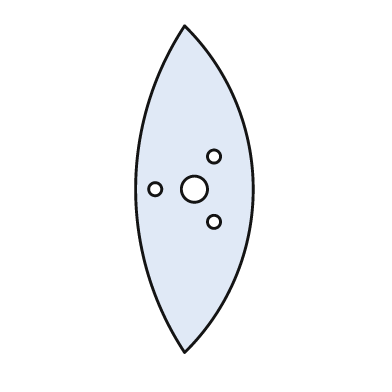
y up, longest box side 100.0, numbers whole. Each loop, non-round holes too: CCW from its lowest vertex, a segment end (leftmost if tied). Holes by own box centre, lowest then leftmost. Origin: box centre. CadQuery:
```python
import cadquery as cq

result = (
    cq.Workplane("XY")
    .moveTo(-3.0, -50.0)
    .threePointArc((18.0, 0.0), (-3.0, 50.0))
    .threePointArc((-18.0, 0.0), (-3.0, -50.0))
    .close()
    .moveTo(6.0, -10.0)
    .circle(2.0)
    .moveTo(-12.0, 0.0)
    .circle(2.0)
    .moveTo(0.0, 0.0)
    .circle(4.0)
    .moveTo(6.0, 10.0)
    .circle(2.0)
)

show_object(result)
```